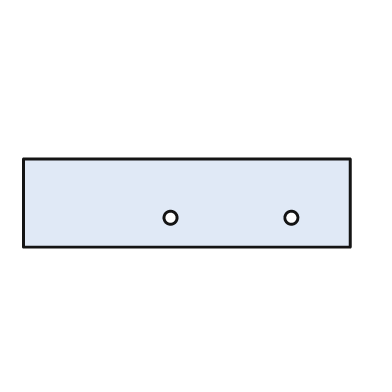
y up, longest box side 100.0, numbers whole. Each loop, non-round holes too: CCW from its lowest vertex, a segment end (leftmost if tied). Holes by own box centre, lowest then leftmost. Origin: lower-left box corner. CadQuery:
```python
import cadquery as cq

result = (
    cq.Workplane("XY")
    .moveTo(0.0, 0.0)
    .lineTo(100.0, 0.0)
    .lineTo(100.0, 27.0)
    .lineTo(0.0, 27.0)
    .close()
    .moveTo(45.0, 9.0)
    .circle(2.0)
    .moveTo(82.0, 9.0)
    .circle(2.0)
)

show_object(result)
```